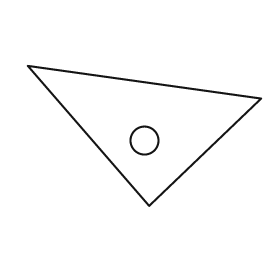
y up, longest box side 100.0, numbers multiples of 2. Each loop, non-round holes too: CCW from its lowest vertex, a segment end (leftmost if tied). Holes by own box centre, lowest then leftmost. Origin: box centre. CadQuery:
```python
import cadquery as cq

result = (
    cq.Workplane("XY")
    .moveTo(2.0, -30.0)
    .lineTo(50.0, 16.0)
    .lineTo(-50.0, 30.0)
    .close()
    .moveTo(0.0, -2.0)
    .circle(6.0)
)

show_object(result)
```